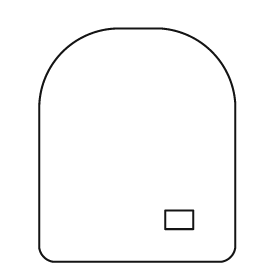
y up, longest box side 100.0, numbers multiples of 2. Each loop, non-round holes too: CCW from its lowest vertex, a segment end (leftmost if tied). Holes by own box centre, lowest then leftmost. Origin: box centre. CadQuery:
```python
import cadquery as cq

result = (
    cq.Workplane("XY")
    .moveTo(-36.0, -50.0)
    .lineTo(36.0, -50.0)
    .threePointArc((40.0, -48.0), (42.0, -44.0))
    .lineTo(42.0, 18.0)
    .threePointArc((32.0, 40.0), (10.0, 50.0))
    .lineTo(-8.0, 50.0)
    .threePointArc((-32.0, 40.0), (-42.0, 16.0))
    .lineTo(-42.0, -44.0)
    .threePointArc((-40.0, -48.0), (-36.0, -50.0))
    .close()
    .moveTo(12.0, -36.0)
    .lineTo(24.0, -36.0)
    .lineTo(24.0, -28.0)
    .lineTo(12.0, -28.0)
    .close()
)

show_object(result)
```